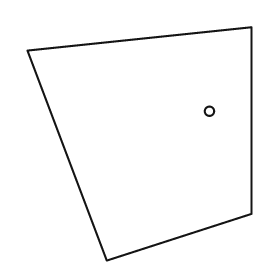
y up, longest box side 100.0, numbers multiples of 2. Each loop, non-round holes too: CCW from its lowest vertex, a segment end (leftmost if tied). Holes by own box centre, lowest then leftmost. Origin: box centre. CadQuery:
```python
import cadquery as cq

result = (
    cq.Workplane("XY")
    .moveTo(-14.0, -50.0)
    .lineTo(48.0, -30.0)
    .lineTo(48.0, 50.0)
    .lineTo(-48.0, 40.0)
    .close()
    .moveTo(30.0, 14.0)
    .circle(2.0)
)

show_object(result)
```